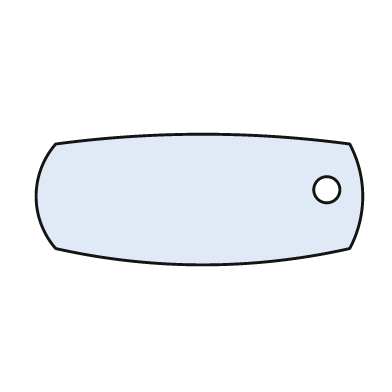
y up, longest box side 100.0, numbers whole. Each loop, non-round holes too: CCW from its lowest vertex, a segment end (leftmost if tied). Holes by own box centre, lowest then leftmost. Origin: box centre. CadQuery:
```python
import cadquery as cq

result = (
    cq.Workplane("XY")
    .moveTo(-44.0, -15.0)
    .threePointArc((1.0, -20.0), (46.0, -15.0))
    .threePointArc((50.0, 1.0), (46.0, 17.0))
    .threePointArc((1.0, 20.0), (-44.0, 17.0))
    .threePointArc((-50.0, 1.0), (-44.0, -15.0))
    .close()
    .moveTo(39.0, 3.0)
    .circle(4.0)
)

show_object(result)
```